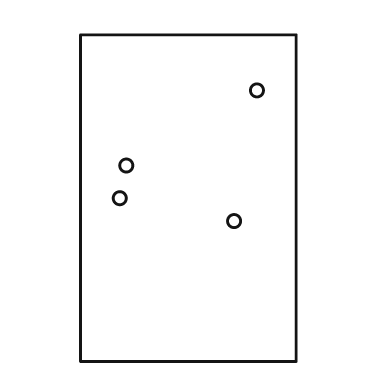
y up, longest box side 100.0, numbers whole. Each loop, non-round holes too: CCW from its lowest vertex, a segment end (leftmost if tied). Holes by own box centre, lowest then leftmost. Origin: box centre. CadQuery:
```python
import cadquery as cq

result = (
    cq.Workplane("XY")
    .moveTo(-33.0, -50.0)
    .lineTo(33.0, -50.0)
    .lineTo(33.0, 50.0)
    .lineTo(-33.0, 50.0)
    .close()
    .moveTo(14.0, -7.0)
    .circle(2.0)
    .moveTo(-21.0, 0.0)
    .circle(2.0)
    .moveTo(-19.0, 10.0)
    .circle(2.0)
    .moveTo(21.0, 33.0)
    .circle(2.0)
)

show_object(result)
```